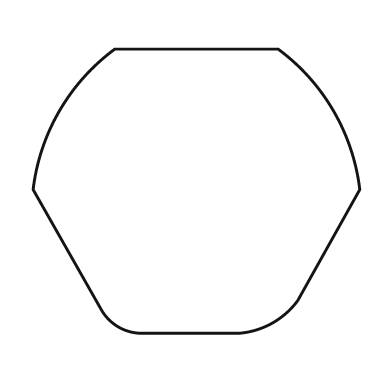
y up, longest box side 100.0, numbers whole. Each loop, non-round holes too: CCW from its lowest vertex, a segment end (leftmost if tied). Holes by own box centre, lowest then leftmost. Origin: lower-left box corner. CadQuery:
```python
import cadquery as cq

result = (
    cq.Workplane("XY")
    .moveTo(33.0, 0.0)
    .lineTo(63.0, 0.0)
    .threePointArc((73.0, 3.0), (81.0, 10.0))
    .lineTo(100.0, 44.0)
    .threePointArc((92.0, 68.0), (75.0, 87.0))
    .lineTo(25.0, 87.0)
    .threePointArc((8.0, 68.0), (0.0, 44.0))
    .lineTo(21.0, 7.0)
    .threePointArc((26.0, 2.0), (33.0, 0.0))
    .close()
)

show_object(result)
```